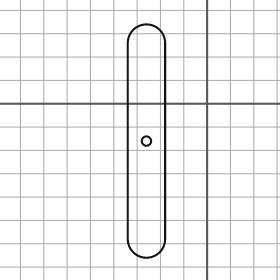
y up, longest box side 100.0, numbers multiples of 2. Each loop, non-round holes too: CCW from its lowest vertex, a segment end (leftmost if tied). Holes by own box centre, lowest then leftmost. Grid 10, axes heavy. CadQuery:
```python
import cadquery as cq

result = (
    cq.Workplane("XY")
    .moveTo(-34.0, -58.0)
    .threePointArc((-26.0, -66.0), (-18.0, -58.0))
    .lineTo(-18.0, 26.0)
    .threePointArc((-26.0, 34.0), (-34.0, 26.0))
    .close()
    .moveTo(-26.0, -16.0)
    .circle(2.0)
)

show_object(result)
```